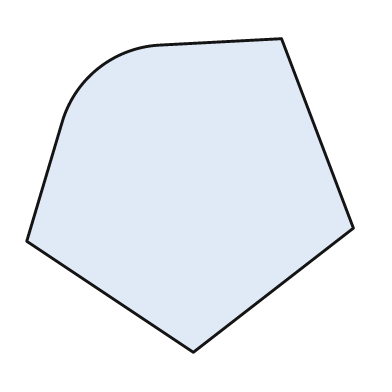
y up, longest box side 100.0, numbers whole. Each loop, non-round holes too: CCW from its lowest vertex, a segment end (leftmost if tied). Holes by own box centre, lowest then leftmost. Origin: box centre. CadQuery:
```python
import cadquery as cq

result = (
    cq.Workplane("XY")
    .moveTo(1.0, -48.0)
    .lineTo(50.0, -10.0)
    .lineTo(28.0, 48.0)
    .lineTo(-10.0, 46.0)
    .threePointArc((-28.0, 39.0), (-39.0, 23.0))
    .lineTo(-50.0, -14.0)
    .close()
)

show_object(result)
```